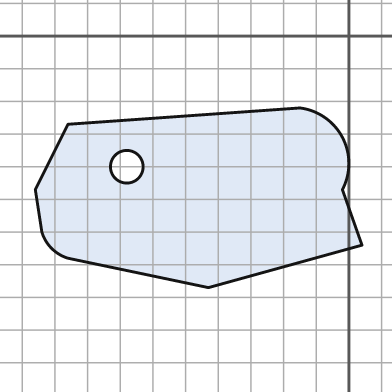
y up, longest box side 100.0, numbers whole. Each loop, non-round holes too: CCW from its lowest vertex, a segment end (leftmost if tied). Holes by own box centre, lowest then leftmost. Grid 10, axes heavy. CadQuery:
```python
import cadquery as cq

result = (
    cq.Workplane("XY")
    .moveTo(-43.0, -77.0)
    .lineTo(4.0, -64.0)
    .lineTo(-2.0, -47.0)
    .threePointArc((-2.0, -31.0), (-15.0, -22.0))
    .lineTo(-86.0, -27.0)
    .lineTo(-96.0, -47.0)
    .lineTo(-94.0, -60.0)
    .threePointArc((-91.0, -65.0), (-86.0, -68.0))
    .close()
    .moveTo(-68.0, -40.0)
    .circle(5.0)
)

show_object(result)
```